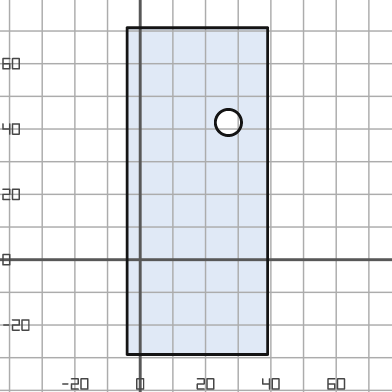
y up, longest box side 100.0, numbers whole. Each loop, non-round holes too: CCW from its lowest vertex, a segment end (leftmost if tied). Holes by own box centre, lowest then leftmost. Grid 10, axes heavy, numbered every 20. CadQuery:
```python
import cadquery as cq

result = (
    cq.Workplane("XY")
    .moveTo(-4.0, -29.0)
    .lineTo(39.0, -29.0)
    .lineTo(39.0, 71.0)
    .lineTo(-4.0, 71.0)
    .close()
    .moveTo(27.0, 42.0)
    .circle(4.0)
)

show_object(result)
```